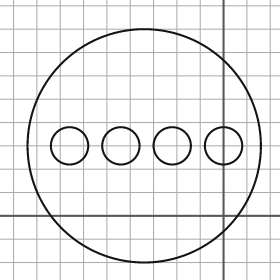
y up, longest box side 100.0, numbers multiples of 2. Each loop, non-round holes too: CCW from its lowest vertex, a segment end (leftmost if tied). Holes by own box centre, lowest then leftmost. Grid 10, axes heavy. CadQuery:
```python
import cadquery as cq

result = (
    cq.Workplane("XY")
    .moveTo(-34.0, 30.0)
    .circle(50.0)
    .moveTo(-66.0, 30.0)
    .circle(8.0)
    .moveTo(-44.0, 30.0)
    .circle(8.0)
    .moveTo(-22.0, 30.0)
    .circle(8.0)
    .moveTo(0.0, 30.0)
    .circle(8.0)
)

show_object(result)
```